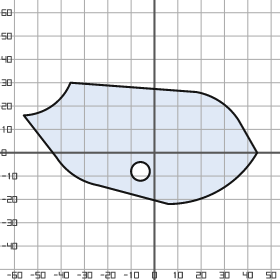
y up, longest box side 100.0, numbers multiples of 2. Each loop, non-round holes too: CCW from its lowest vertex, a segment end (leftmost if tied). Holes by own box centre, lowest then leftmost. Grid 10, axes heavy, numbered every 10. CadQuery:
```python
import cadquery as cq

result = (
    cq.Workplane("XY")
    .moveTo(6.0, -22.0)
    .threePointArc((28.0, -16.0), (44.0, 0.0))
    .lineTo(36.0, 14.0)
    .threePointArc((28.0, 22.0), (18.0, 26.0))
    .lineTo(-36.0, 30.0)
    .threePointArc((-44.0, 20.0), (-56.0, 16.0))
    .lineTo(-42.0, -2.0)
    .threePointArc((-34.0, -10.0), (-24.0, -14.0))
    .close()
    .moveTo(-6.0, -8.0)
    .circle(4.0)
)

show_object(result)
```